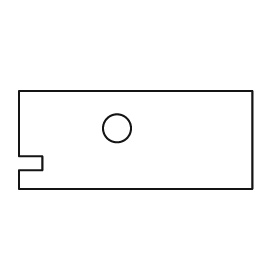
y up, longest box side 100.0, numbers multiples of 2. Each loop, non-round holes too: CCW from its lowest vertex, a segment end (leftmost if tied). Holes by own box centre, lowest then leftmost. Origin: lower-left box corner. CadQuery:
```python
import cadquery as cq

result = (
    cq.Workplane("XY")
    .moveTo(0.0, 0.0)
    .lineTo(100.0, 0.0)
    .lineTo(100.0, 42.0)
    .lineTo(0.0, 42.0)
    .lineTo(0.0, 14.0)
    .lineTo(10.0, 14.0)
    .lineTo(10.0, 8.0)
    .lineTo(0.0, 8.0)
    .close()
    .moveTo(42.0, 26.0)
    .circle(6.0)
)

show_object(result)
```